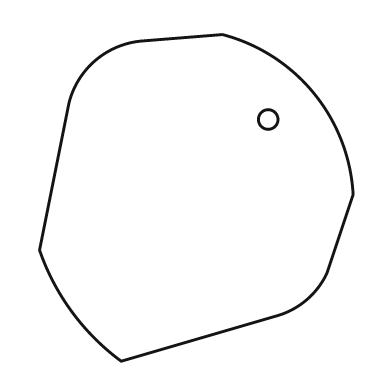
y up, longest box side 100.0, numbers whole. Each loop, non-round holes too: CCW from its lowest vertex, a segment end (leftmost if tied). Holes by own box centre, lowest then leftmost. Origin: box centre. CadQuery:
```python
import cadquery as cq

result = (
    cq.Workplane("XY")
    .moveTo(-23.0, -50.0)
    .lineTo(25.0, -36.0)
    .threePointArc((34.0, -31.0), (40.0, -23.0))
    .lineTo(48.0, 1.0)
    .threePointArc((36.0, 32.0), (8.0, 50.0))
    .lineTo(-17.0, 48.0)
    .threePointArc((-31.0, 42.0), (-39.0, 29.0))
    .lineTo(-48.0, -16.0)
    .threePointArc((-38.0, -35.0), (-23.0, -50.0))
    .close()
    .moveTo(22.0, 24.0)
    .circle(3.0)
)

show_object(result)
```